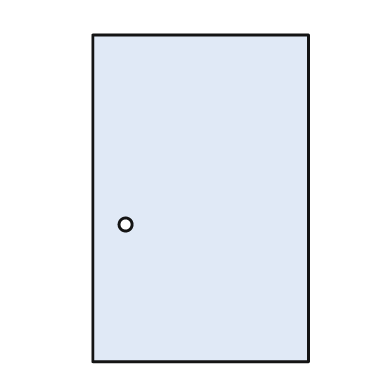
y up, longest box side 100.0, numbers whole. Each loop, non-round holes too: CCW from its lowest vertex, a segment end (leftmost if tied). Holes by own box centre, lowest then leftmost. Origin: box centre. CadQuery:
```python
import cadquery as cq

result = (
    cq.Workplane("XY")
    .moveTo(-33.0, -50.0)
    .lineTo(33.0, -50.0)
    .lineTo(33.0, 50.0)
    .lineTo(-33.0, 50.0)
    .close()
    .moveTo(-23.0, -8.0)
    .circle(2.0)
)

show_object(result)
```